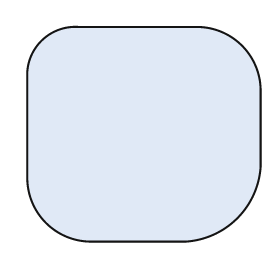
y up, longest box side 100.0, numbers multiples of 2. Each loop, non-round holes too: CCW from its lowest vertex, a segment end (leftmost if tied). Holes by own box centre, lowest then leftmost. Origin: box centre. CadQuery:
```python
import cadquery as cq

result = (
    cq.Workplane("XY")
    .moveTo(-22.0, -46.0)
    .lineTo(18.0, -46.0)
    .threePointArc((40.0, -36.0), (50.0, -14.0))
    .lineTo(50.0, 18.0)
    .threePointArc((42.0, 38.0), (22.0, 46.0))
    .lineTo(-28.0, 46.0)
    .threePointArc((-44.0, 40.0), (-50.0, 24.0))
    .lineTo(-50.0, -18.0)
    .threePointArc((-42.0, -38.0), (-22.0, -46.0))
    .close()
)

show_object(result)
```